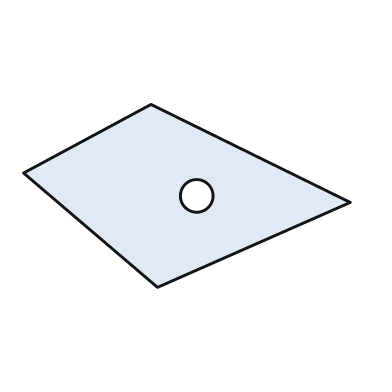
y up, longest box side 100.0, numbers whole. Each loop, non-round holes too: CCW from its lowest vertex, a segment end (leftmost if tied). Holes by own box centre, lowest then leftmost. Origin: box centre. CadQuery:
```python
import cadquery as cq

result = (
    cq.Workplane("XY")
    .moveTo(-9.0, -28.0)
    .lineTo(50.0, -2.0)
    .lineTo(-11.0, 28.0)
    .lineTo(-50.0, 7.0)
    .close()
    .moveTo(3.0, 0.0)
    .circle(5.0)
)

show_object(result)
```